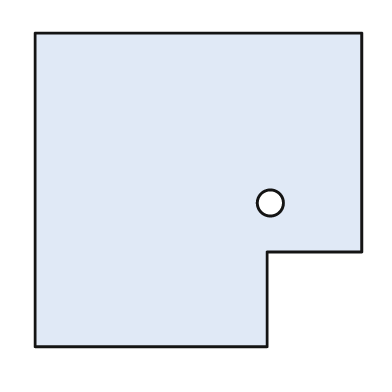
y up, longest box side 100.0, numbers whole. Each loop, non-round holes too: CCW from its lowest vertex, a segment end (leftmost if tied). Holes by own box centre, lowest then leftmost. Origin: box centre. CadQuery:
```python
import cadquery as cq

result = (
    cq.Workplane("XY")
    .moveTo(-50.0, -48.0)
    .lineTo(21.0, -48.0)
    .lineTo(21.0, -19.0)
    .lineTo(50.0, -19.0)
    .lineTo(50.0, 48.0)
    .lineTo(-50.0, 48.0)
    .close()
    .moveTo(22.0, -4.0)
    .circle(4.0)
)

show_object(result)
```